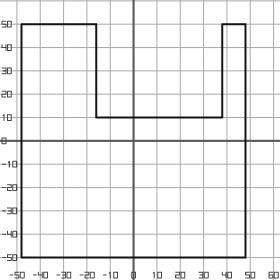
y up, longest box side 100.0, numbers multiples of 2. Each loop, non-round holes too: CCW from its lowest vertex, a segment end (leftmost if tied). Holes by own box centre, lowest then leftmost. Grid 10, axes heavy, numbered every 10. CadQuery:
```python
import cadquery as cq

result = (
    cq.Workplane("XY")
    .moveTo(-48.0, -50.0)
    .lineTo(48.0, -50.0)
    .lineTo(48.0, 50.0)
    .lineTo(38.0, 50.0)
    .lineTo(38.0, 10.0)
    .lineTo(-16.0, 10.0)
    .lineTo(-16.0, 50.0)
    .lineTo(-48.0, 50.0)
    .close()
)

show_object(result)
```